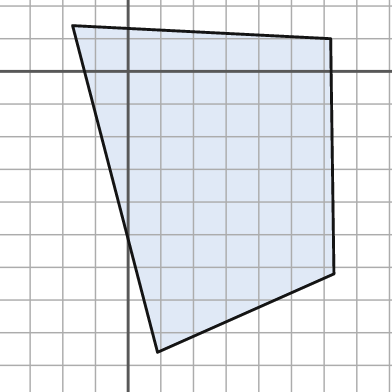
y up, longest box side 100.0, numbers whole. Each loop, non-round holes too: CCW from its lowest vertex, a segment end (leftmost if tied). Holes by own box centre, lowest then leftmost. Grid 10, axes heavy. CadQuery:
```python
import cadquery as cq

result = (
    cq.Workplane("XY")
    .moveTo(9.0, -86.0)
    .lineTo(63.0, -62.0)
    .lineTo(62.0, 10.0)
    .lineTo(-17.0, 14.0)
    .close()
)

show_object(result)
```